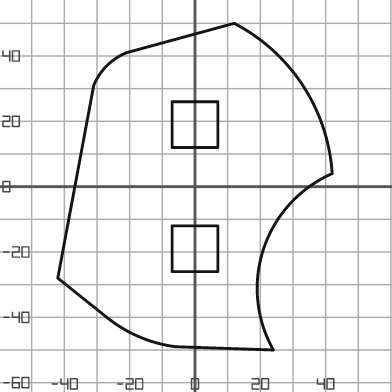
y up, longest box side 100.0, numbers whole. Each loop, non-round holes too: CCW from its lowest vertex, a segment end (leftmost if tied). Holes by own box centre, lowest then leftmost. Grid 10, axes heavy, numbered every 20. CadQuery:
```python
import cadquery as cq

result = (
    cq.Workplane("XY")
    .moveTo(24.0, -50.0)
    .threePointArc((21.0, -19.0), (42.0, 4.0))
    .threePointArc((33.0, 31.0), (12.0, 50.0))
    .lineTo(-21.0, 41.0)
    .threePointArc((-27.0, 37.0), (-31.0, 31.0))
    .lineTo(-42.0, -28.0)
    .lineTo(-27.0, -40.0)
    .threePointArc((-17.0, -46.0), (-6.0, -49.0))
    .close()
    .moveTo(-7.0, -26.0)
    .lineTo(7.0, -26.0)
    .lineTo(7.0, -12.0)
    .lineTo(-7.0, -12.0)
    .close()
    .moveTo(-7.0, 12.0)
    .lineTo(7.0, 12.0)
    .lineTo(7.0, 26.0)
    .lineTo(-7.0, 26.0)
    .close()
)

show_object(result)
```